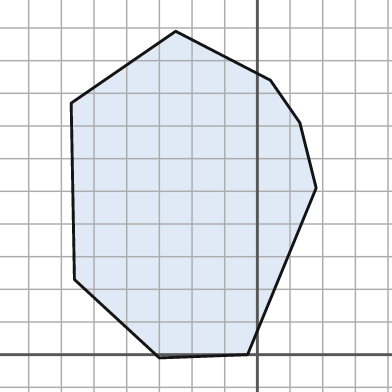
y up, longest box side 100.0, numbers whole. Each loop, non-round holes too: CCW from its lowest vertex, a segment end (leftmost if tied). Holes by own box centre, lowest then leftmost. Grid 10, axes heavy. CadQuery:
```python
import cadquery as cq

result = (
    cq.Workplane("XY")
    .moveTo(-30.0, -1.0)
    .lineTo(-3.0, 0.0)
    .lineTo(18.0, 51.0)
    .lineTo(13.0, 71.0)
    .lineTo(4.0, 84.0)
    .lineTo(-25.0, 99.0)
    .lineTo(-57.0, 77.0)
    .lineTo(-56.0, 23.0)
    .close()
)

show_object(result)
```